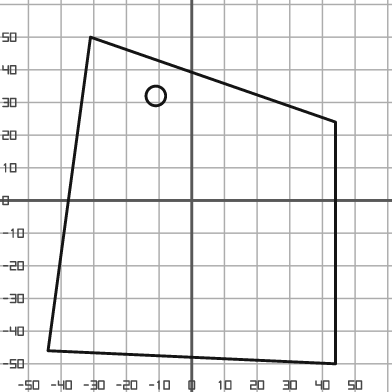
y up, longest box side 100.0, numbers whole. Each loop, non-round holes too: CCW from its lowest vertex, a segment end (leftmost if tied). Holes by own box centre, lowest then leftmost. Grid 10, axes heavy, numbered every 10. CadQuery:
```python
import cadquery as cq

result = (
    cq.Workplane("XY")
    .moveTo(44.0, -50.0)
    .lineTo(44.0, 24.0)
    .lineTo(-31.0, 50.0)
    .lineTo(-44.0, -46.0)
    .close()
    .moveTo(-11.0, 32.0)
    .circle(3.0)
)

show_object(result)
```